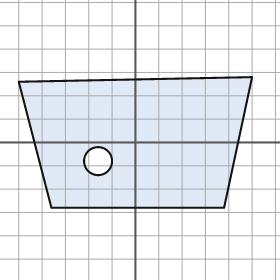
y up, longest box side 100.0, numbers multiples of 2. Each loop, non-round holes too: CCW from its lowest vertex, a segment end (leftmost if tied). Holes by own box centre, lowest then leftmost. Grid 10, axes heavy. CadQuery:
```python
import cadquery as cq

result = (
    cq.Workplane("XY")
    .moveTo(-36.0, -28.0)
    .lineTo(38.0, -28.0)
    .lineTo(50.0, 28.0)
    .lineTo(-50.0, 26.0)
    .close()
    .moveTo(-16.0, -8.0)
    .circle(6.0)
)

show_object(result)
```